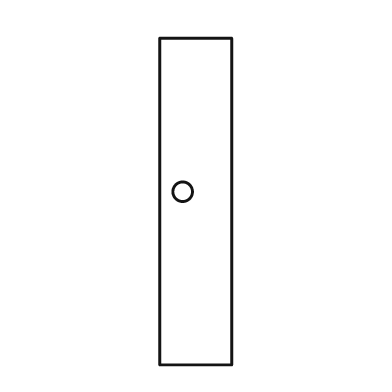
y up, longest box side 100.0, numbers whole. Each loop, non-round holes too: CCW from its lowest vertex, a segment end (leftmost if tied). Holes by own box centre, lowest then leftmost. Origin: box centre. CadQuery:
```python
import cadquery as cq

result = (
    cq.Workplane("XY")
    .moveTo(-11.0, -50.0)
    .lineTo(11.0, -50.0)
    .lineTo(11.0, 50.0)
    .lineTo(-11.0, 50.0)
    .close()
    .moveTo(-4.0, 3.0)
    .circle(3.0)
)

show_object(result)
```